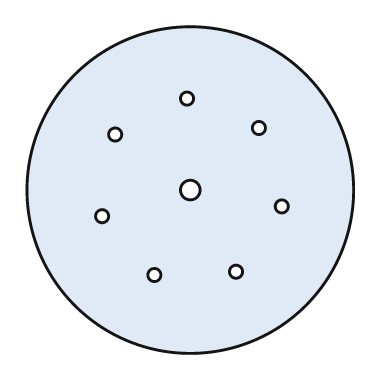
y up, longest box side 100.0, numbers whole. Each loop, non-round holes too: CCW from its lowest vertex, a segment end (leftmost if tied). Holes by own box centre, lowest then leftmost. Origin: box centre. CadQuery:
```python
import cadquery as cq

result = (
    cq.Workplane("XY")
    .moveTo(0.0, 0.0)
    .circle(50.0)
    .moveTo(-11.0, -26.0)
    .circle(2.0)
    .moveTo(14.0, -25.0)
    .circle(2.0)
    .moveTo(-27.0, -8.0)
    .circle(2.0)
    .moveTo(28.0, -5.0)
    .circle(2.0)
    .moveTo(0.0, 0.0)
    .circle(3.0)
    .moveTo(-23.0, 17.0)
    .circle(2.0)
    .moveTo(21.0, 19.0)
    .circle(2.0)
    .moveTo(-1.0, 28.0)
    .circle(2.0)
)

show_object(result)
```